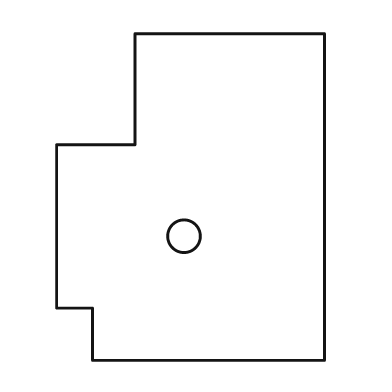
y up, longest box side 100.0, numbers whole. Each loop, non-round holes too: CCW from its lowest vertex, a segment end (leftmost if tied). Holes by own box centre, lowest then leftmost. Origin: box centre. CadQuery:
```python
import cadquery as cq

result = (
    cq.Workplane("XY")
    .moveTo(-30.0, -50.0)
    .lineTo(41.0, -50.0)
    .lineTo(41.0, 50.0)
    .lineTo(-17.0, 50.0)
    .lineTo(-17.0, 16.0)
    .lineTo(-41.0, 16.0)
    .lineTo(-41.0, -34.0)
    .lineTo(-30.0, -34.0)
    .close()
    .moveTo(-2.0, -12.0)
    .circle(5.0)
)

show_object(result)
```